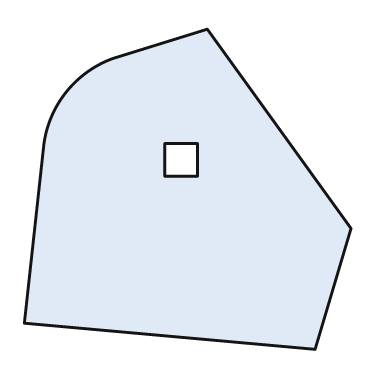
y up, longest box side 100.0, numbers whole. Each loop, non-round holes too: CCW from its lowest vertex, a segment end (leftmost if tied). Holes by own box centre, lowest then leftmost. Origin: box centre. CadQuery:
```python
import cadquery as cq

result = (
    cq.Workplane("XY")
    .moveTo(39.0, -49.0)
    .lineTo(50.0, -12.0)
    .lineTo(6.0, 49.0)
    .lineTo(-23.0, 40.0)
    .threePointArc((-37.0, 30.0), (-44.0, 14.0))
    .lineTo(-50.0, -41.0)
    .close()
    .moveTo(-7.0, 4.0)
    .lineTo(3.0, 4.0)
    .lineTo(3.0, 14.0)
    .lineTo(-7.0, 14.0)
    .close()
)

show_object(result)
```